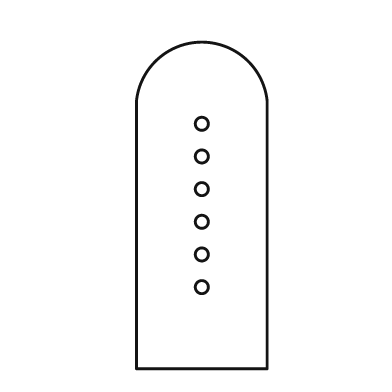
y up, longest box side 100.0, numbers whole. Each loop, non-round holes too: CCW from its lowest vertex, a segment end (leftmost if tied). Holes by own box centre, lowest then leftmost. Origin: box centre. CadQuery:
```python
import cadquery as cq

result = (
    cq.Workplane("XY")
    .moveTo(-20.0, -50.0)
    .lineTo(20.0, -50.0)
    .lineTo(20.0, 32.0)
    .threePointArc((0.0, 50.0), (-20.0, 32.0))
    .close()
    .moveTo(0.0, -25.0)
    .circle(2.0)
    .moveTo(0.0, -15.0)
    .circle(2.0)
    .moveTo(0.0, -5.0)
    .circle(2.0)
    .moveTo(0.0, 5.0)
    .circle(2.0)
    .moveTo(0.0, 15.0)
    .circle(2.0)
    .moveTo(0.0, 25.0)
    .circle(2.0)
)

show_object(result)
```